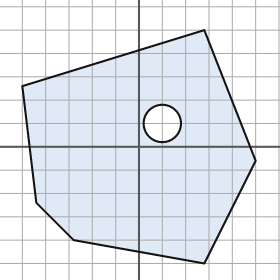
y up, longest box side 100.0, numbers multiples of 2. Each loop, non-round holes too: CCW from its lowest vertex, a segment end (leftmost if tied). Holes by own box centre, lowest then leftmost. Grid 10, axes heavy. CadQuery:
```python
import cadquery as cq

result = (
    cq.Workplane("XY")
    .moveTo(28.0, -50.0)
    .lineTo(50.0, -6.0)
    .lineTo(28.0, 50.0)
    .lineTo(-50.0, 26.0)
    .lineTo(-44.0, -24.0)
    .lineTo(-28.0, -40.0)
    .close()
    .moveTo(10.0, 10.0)
    .circle(8.0)
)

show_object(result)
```